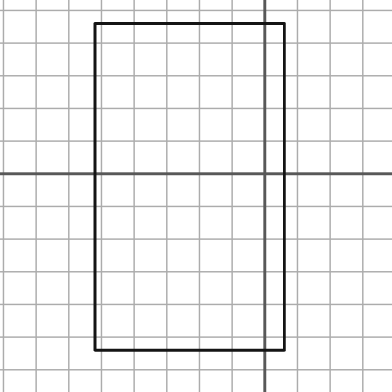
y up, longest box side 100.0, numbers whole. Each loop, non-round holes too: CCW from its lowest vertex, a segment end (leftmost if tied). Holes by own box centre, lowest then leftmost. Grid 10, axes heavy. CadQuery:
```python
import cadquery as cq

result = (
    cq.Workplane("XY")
    .moveTo(-52.0, -54.0)
    .lineTo(6.0, -54.0)
    .lineTo(6.0, 46.0)
    .lineTo(-52.0, 46.0)
    .close()
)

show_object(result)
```